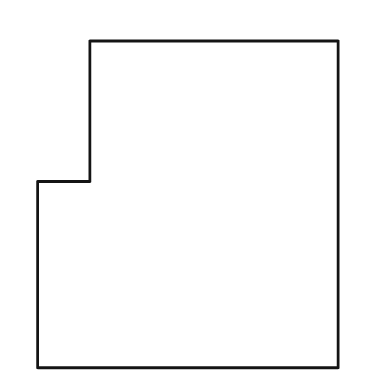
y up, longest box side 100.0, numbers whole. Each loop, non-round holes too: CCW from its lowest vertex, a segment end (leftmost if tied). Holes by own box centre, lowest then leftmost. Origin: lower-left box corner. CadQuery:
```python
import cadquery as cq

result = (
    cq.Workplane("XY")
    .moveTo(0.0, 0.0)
    .lineTo(92.0, 0.0)
    .lineTo(92.0, 100.0)
    .lineTo(16.0, 100.0)
    .lineTo(16.0, 57.0)
    .lineTo(0.0, 57.0)
    .close()
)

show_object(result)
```